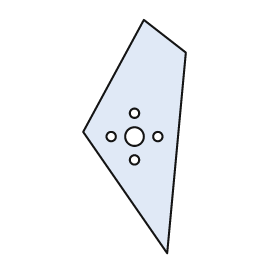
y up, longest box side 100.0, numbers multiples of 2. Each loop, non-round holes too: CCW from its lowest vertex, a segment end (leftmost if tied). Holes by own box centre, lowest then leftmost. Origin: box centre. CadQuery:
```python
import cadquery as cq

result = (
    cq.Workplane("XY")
    .moveTo(14.0, -50.0)
    .lineTo(22.0, 36.0)
    .lineTo(4.0, 50.0)
    .lineTo(-22.0, 2.0)
    .close()
    .moveTo(0.0, -10.0)
    .circle(2.0)
    .moveTo(-10.0, 0.0)
    .circle(2.0)
    .moveTo(0.0, 0.0)
    .circle(4.0)
    .moveTo(10.0, 0.0)
    .circle(2.0)
    .moveTo(0.0, 10.0)
    .circle(2.0)
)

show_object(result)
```